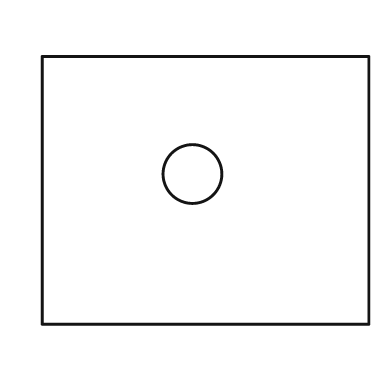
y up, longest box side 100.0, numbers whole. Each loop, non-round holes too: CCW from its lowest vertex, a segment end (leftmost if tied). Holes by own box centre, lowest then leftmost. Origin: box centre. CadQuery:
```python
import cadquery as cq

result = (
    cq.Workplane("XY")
    .moveTo(-50.0, -41.0)
    .lineTo(50.0, -41.0)
    .lineTo(50.0, 41.0)
    .lineTo(-50.0, 41.0)
    .close()
    .moveTo(-4.0, 5.0)
    .circle(9.0)
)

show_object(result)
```